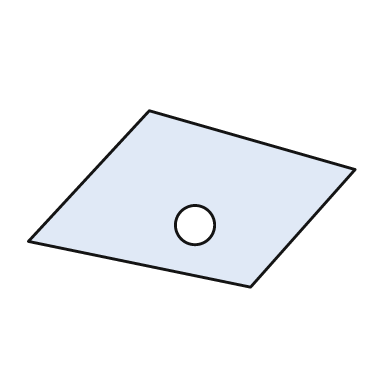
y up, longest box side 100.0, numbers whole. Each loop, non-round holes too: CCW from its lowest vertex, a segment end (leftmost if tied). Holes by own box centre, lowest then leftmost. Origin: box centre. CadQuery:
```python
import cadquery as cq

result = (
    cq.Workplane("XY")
    .moveTo(18.0, -27.0)
    .lineTo(50.0, 9.0)
    .lineTo(-13.0, 27.0)
    .lineTo(-50.0, -13.0)
    .close()
    .moveTo(1.0, -8.0)
    .circle(6.0)
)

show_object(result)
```